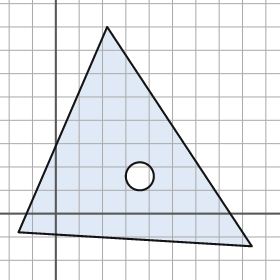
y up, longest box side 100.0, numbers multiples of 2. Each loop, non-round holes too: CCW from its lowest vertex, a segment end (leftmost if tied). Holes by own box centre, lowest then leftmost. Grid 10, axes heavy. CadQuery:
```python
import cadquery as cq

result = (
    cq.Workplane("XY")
    .moveTo(84.0, -14.0)
    .lineTo(22.0, 80.0)
    .lineTo(-16.0, -8.0)
    .close()
    .moveTo(36.0, 16.0)
    .circle(6.0)
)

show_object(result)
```